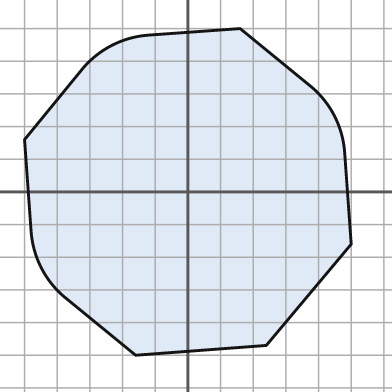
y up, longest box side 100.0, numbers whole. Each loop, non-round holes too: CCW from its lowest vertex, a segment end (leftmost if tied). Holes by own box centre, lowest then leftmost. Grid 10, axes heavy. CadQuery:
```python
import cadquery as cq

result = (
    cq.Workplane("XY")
    .moveTo(-16.0, -50.0)
    .lineTo(24.0, -47.0)
    .lineTo(50.0, -16.0)
    .lineTo(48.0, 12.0)
    .threePointArc((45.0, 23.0), (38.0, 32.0))
    .lineTo(16.0, 50.0)
    .lineTo(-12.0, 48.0)
    .threePointArc((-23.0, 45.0), (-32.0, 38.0))
    .lineTo(-50.0, 16.0)
    .lineTo(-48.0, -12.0)
    .threePointArc((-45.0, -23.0), (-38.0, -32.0))
    .close()
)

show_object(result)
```